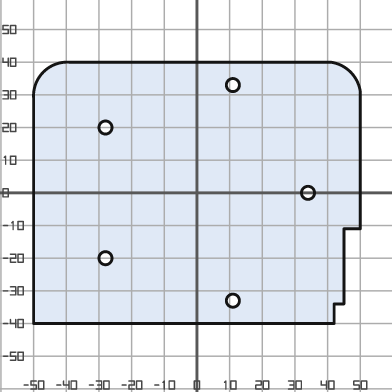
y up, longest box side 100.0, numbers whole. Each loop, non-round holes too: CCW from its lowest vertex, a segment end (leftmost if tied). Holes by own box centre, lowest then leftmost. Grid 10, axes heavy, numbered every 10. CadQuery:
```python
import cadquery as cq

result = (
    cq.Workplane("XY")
    .moveTo(-50.0, -40.0)
    .lineTo(42.0, -40.0)
    .lineTo(42.0, -34.0)
    .lineTo(45.0, -34.0)
    .lineTo(45.0, -11.0)
    .lineTo(50.0, -11.0)
    .lineTo(50.0, 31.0)
    .threePointArc((47.0, 37.0), (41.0, 40.0))
    .lineTo(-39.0, 40.0)
    .threePointArc((-47.0, 37.0), (-50.0, 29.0))
    .close()
    .moveTo(11.0, -33.0)
    .circle(2.0)
    .moveTo(-28.0, -20.0)
    .circle(2.0)
    .moveTo(34.0, 0.0)
    .circle(2.0)
    .moveTo(-28.0, 20.0)
    .circle(2.0)
    .moveTo(11.0, 33.0)
    .circle(2.0)
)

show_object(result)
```